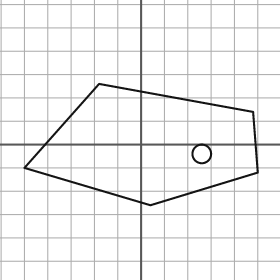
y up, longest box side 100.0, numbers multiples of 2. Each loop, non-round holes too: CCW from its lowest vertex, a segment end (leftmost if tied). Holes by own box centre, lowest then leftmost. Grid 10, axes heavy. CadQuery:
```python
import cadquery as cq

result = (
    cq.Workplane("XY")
    .moveTo(4.0, -26.0)
    .lineTo(50.0, -12.0)
    .lineTo(48.0, 14.0)
    .lineTo(-18.0, 26.0)
    .lineTo(-50.0, -10.0)
    .close()
    .moveTo(26.0, -4.0)
    .circle(4.0)
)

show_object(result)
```